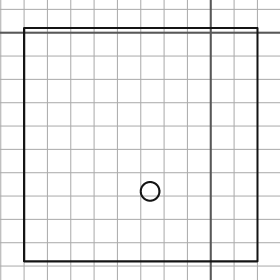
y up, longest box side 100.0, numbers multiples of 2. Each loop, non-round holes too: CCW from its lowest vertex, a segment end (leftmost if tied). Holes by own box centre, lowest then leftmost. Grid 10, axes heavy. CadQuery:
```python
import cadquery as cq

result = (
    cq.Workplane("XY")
    .moveTo(-80.0, -98.0)
    .lineTo(20.0, -98.0)
    .lineTo(20.0, 2.0)
    .lineTo(-80.0, 2.0)
    .close()
    .moveTo(-26.0, -68.0)
    .circle(4.0)
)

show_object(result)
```